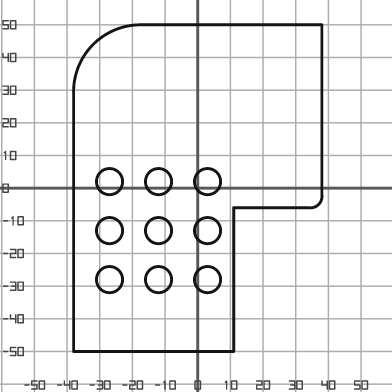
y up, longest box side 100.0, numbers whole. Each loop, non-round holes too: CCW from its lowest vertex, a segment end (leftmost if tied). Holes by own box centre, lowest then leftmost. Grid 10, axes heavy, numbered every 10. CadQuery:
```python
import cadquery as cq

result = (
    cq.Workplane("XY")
    .moveTo(-38.0, -50.0)
    .lineTo(11.0, -50.0)
    .lineTo(11.0, -6.0)
    .lineTo(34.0, -6.0)
    .threePointArc((37.0, -5.0), (38.0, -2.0))
    .lineTo(38.0, 50.0)
    .lineTo(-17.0, 50.0)
    .threePointArc((-32.0, 44.0), (-38.0, 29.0))
    .close()
    .moveTo(-27.0, -28.0)
    .circle(4.0)
    .moveTo(-12.0, -28.0)
    .circle(4.0)
    .moveTo(3.0, -28.0)
    .circle(4.0)
    .moveTo(-27.0, -13.0)
    .circle(4.0)
    .moveTo(-12.0, -13.0)
    .circle(4.0)
    .moveTo(3.0, -13.0)
    .circle(4.0)
    .moveTo(-27.0, 2.0)
    .circle(4.0)
    .moveTo(-12.0, 2.0)
    .circle(4.0)
    .moveTo(3.0, 2.0)
    .circle(4.0)
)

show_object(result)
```